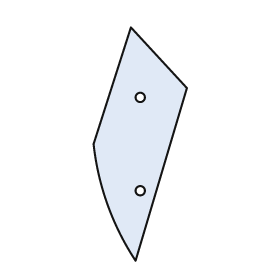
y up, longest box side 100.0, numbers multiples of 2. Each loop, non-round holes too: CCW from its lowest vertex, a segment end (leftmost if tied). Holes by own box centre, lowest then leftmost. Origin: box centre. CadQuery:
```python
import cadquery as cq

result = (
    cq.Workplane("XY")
    .moveTo(-2.0, -50.0)
    .lineTo(20.0, 24.0)
    .lineTo(-4.0, 50.0)
    .lineTo(-20.0, 0.0)
    .threePointArc((-14.0, -26.0), (-2.0, -50.0))
    .close()
    .moveTo(0.0, -20.0)
    .circle(2.0)
    .moveTo(0.0, 20.0)
    .circle(2.0)
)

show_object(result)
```